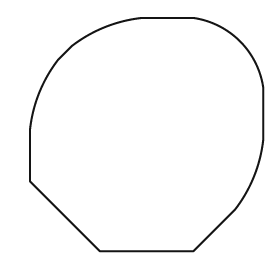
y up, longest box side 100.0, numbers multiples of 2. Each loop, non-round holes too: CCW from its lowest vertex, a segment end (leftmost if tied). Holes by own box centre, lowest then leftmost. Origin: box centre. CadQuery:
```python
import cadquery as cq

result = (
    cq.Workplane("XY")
    .moveTo(-20.0, -50.0)
    .lineTo(20.0, -50.0)
    .lineTo(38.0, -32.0)
    .threePointArc((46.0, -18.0), (50.0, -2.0))
    .lineTo(50.0, 20.0)
    .threePointArc((40.0, 40.0), (20.0, 50.0))
    .lineTo(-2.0, 50.0)
    .threePointArc((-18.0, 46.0), (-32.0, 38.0))
    .lineTo(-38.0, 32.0)
    .threePointArc((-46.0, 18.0), (-50.0, 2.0))
    .lineTo(-50.0, -20.0)
    .close()
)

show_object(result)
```